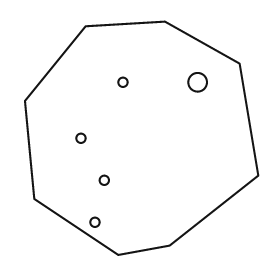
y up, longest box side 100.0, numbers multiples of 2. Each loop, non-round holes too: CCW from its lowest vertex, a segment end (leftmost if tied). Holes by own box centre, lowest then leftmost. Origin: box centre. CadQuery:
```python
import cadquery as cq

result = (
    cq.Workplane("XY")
    .moveTo(-10.0, -50.0)
    .lineTo(12.0, -46.0)
    .lineTo(50.0, -16.0)
    .lineTo(42.0, 32.0)
    .lineTo(10.0, 50.0)
    .lineTo(-24.0, 48.0)
    .lineTo(-50.0, 16.0)
    .lineTo(-46.0, -26.0)
    .close()
    .moveTo(-20.0, -36.0)
    .circle(2.0)
    .moveTo(-16.0, -18.0)
    .circle(2.0)
    .moveTo(-26.0, 0.0)
    .circle(2.0)
    .moveTo(-8.0, 24.0)
    .circle(2.0)
    .moveTo(24.0, 24.0)
    .circle(4.0)
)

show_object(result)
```